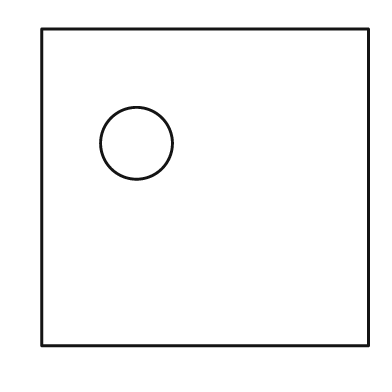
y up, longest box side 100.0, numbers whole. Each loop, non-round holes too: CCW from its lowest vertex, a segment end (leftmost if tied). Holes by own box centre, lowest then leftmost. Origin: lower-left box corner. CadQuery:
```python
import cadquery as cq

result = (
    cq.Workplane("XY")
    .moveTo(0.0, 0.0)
    .lineTo(100.0, 0.0)
    .lineTo(100.0, 97.0)
    .lineTo(0.0, 97.0)
    .close()
    .moveTo(29.0, 62.0)
    .circle(11.0)
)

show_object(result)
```